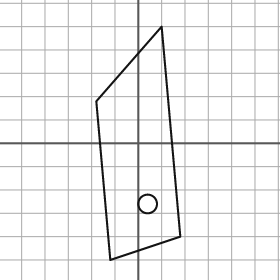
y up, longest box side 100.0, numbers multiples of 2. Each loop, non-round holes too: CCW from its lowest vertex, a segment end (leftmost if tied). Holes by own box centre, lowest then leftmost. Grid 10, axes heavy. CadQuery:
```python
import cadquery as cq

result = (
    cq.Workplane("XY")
    .moveTo(-12.0, -50.0)
    .lineTo(18.0, -40.0)
    .lineTo(10.0, 50.0)
    .lineTo(-18.0, 18.0)
    .close()
    .moveTo(4.0, -26.0)
    .circle(4.0)
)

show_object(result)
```